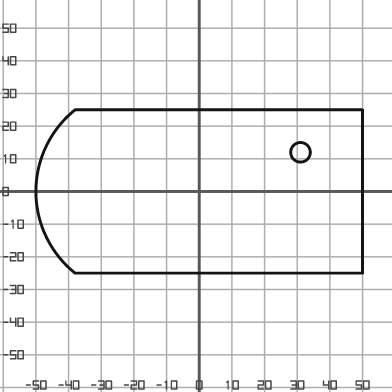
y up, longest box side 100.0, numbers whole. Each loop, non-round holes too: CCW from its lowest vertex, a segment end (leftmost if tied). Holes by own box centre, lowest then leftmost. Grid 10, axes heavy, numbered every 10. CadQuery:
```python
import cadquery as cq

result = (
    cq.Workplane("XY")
    .moveTo(-38.0, -25.0)
    .lineTo(50.0, -25.0)
    .lineTo(50.0, 25.0)
    .lineTo(-38.0, 25.0)
    .threePointArc((-50.0, 0.0), (-38.0, -25.0))
    .close()
    .moveTo(31.0, 12.0)
    .circle(3.0)
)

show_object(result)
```